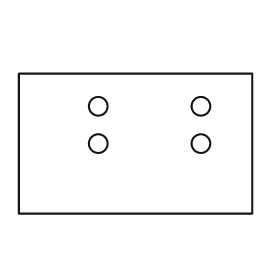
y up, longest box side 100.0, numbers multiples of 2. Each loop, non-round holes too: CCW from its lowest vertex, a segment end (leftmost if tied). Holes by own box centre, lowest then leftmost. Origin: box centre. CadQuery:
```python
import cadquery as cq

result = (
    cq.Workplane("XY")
    .moveTo(-50.0, -30.0)
    .lineTo(50.0, -30.0)
    .lineTo(50.0, 30.0)
    .lineTo(-50.0, 30.0)
    .close()
    .moveTo(-16.0, 0.0)
    .circle(4.0)
    .moveTo(28.0, 0.0)
    .circle(4.0)
    .moveTo(-16.0, 16.0)
    .circle(4.0)
    .moveTo(28.0, 16.0)
    .circle(4.0)
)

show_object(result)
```